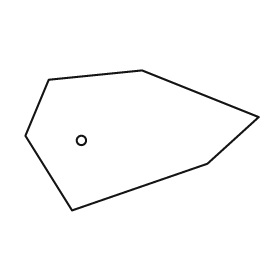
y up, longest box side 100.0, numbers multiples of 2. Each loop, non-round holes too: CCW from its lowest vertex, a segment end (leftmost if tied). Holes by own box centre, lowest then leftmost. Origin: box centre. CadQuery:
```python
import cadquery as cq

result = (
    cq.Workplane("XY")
    .moveTo(-30.0, -30.0)
    .lineTo(28.0, -10.0)
    .lineTo(50.0, 10.0)
    .lineTo(0.0, 30.0)
    .lineTo(-40.0, 26.0)
    .lineTo(-50.0, 2.0)
    .close()
    .moveTo(-26.0, 0.0)
    .circle(2.0)
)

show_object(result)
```